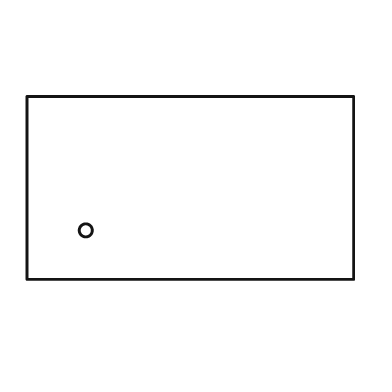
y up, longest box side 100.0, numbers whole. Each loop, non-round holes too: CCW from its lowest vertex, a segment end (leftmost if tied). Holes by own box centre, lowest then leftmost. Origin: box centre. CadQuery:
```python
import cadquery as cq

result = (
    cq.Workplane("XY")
    .moveTo(-50.0, -28.0)
    .lineTo(50.0, -28.0)
    .lineTo(50.0, 28.0)
    .lineTo(-50.0, 28.0)
    .close()
    .moveTo(-32.0, -13.0)
    .circle(2.0)
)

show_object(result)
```